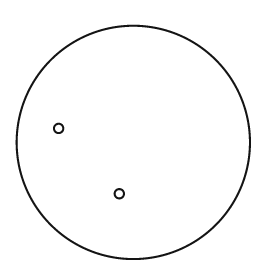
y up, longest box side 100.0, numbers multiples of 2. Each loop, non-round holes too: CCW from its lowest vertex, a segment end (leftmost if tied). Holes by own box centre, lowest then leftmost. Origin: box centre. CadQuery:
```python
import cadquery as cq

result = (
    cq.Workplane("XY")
    .moveTo(0.0, 0.0)
    .circle(50.0)
    .moveTo(-6.0, -22.0)
    .circle(2.0)
    .moveTo(-32.0, 6.0)
    .circle(2.0)
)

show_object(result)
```